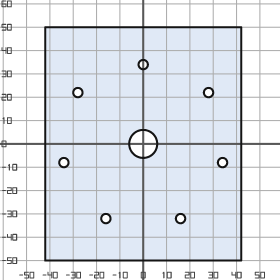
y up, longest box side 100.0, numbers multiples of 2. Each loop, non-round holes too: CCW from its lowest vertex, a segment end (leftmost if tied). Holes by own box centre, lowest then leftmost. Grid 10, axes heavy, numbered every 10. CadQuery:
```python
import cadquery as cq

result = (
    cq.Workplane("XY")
    .moveTo(-42.0, -50.0)
    .lineTo(42.0, -50.0)
    .lineTo(42.0, 50.0)
    .lineTo(-42.0, 50.0)
    .close()
    .moveTo(-16.0, -32.0)
    .circle(2.0)
    .moveTo(16.0, -32.0)
    .circle(2.0)
    .moveTo(-34.0, -8.0)
    .circle(2.0)
    .moveTo(34.0, -8.0)
    .circle(2.0)
    .moveTo(0.0, 0.0)
    .circle(6.0)
    .moveTo(-28.0, 22.0)
    .circle(2.0)
    .moveTo(28.0, 22.0)
    .circle(2.0)
    .moveTo(0.0, 34.0)
    .circle(2.0)
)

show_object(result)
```